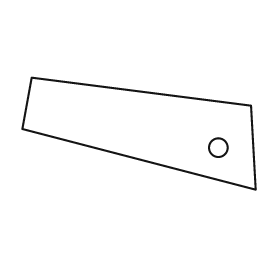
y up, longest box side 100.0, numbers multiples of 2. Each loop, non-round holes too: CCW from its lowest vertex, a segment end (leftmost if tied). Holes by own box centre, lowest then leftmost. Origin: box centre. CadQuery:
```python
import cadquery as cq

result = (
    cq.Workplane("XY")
    .moveTo(50.0, -24.0)
    .lineTo(48.0, 12.0)
    .lineTo(-46.0, 24.0)
    .lineTo(-50.0, 2.0)
    .close()
    .moveTo(34.0, -6.0)
    .circle(4.0)
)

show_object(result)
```